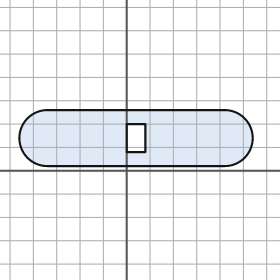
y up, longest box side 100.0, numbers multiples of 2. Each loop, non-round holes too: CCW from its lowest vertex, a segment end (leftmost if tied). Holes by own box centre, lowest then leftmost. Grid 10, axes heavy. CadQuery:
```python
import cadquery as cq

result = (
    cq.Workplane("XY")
    .moveTo(-34.0, 2.0)
    .lineTo(42.0, 2.0)
    .threePointArc((54.0, 14.0), (42.0, 26.0))
    .lineTo(-34.0, 26.0)
    .threePointArc((-46.0, 14.0), (-34.0, 2.0))
    .close()
    .moveTo(0.0, 8.0)
    .lineTo(8.0, 8.0)
    .lineTo(8.0, 20.0)
    .lineTo(0.0, 20.0)
    .close()
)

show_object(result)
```